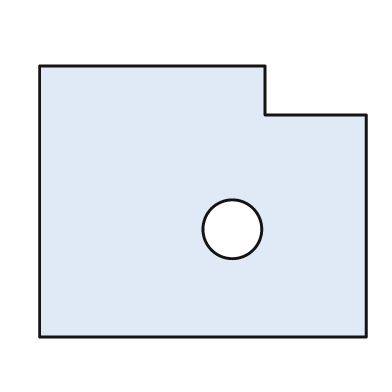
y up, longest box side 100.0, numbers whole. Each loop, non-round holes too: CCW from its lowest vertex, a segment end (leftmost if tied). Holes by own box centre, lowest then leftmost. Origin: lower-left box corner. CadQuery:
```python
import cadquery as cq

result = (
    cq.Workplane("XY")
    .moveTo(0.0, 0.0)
    .lineTo(100.0, 0.0)
    .lineTo(100.0, 68.0)
    .lineTo(69.0, 68.0)
    .lineTo(69.0, 83.0)
    .lineTo(0.0, 83.0)
    .close()
    .moveTo(59.0, 33.0)
    .circle(9.0)
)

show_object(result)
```